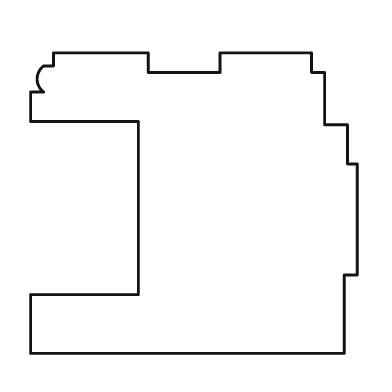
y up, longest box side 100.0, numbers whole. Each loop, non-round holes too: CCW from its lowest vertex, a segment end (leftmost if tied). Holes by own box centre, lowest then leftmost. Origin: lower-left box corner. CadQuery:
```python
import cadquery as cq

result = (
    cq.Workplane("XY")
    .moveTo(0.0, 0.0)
    .lineTo(96.0, 0.0)
    .lineTo(96.0, 24.0)
    .lineTo(100.0, 24.0)
    .lineTo(100.0, 58.0)
    .lineTo(97.0, 58.0)
    .lineTo(97.0, 70.0)
    .lineTo(90.0, 70.0)
    .lineTo(90.0, 86.0)
    .lineTo(86.0, 86.0)
    .lineTo(86.0, 92.0)
    .lineTo(58.0, 92.0)
    .lineTo(58.0, 86.0)
    .lineTo(36.0, 86.0)
    .lineTo(36.0, 92.0)
    .lineTo(7.0, 92.0)
    .lineTo(7.0, 88.0)
    .lineTo(4.0, 88.0)
    .threePointArc((2.0, 84.0), (4.0, 80.0))
    .lineTo(0.0, 80.0)
    .lineTo(0.0, 71.0)
    .lineTo(33.0, 71.0)
    .lineTo(33.0, 18.0)
    .lineTo(0.0, 18.0)
    .close()
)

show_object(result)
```